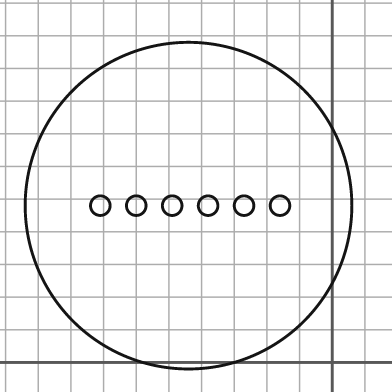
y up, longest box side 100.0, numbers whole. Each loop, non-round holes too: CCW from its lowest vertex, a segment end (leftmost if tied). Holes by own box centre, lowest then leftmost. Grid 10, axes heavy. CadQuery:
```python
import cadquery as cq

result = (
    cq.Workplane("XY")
    .moveTo(-44.0, 48.0)
    .circle(50.0)
    .moveTo(-71.0, 48.0)
    .circle(3.0)
    .moveTo(-60.0, 48.0)
    .circle(3.0)
    .moveTo(-49.0, 48.0)
    .circle(3.0)
    .moveTo(-38.0, 48.0)
    .circle(3.0)
    .moveTo(-27.0, 48.0)
    .circle(3.0)
    .moveTo(-16.0, 48.0)
    .circle(3.0)
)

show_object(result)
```